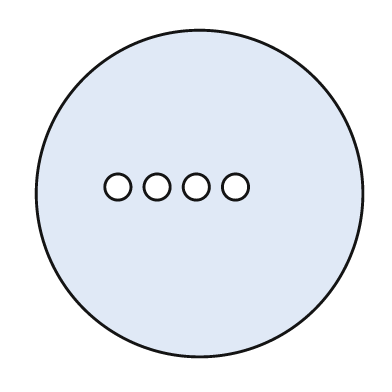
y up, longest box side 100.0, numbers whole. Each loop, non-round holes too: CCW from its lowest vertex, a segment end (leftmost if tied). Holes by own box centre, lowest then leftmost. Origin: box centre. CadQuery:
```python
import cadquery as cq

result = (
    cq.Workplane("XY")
    .moveTo(0.0, 0.0)
    .circle(50.0)
    .moveTo(-25.0, 2.0)
    .circle(4.0)
    .moveTo(-13.0, 2.0)
    .circle(4.0)
    .moveTo(-1.0, 2.0)
    .circle(4.0)
    .moveTo(11.0, 2.0)
    .circle(4.0)
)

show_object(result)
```